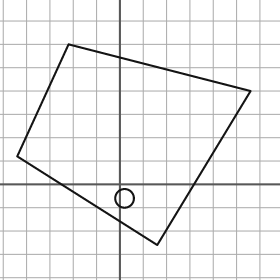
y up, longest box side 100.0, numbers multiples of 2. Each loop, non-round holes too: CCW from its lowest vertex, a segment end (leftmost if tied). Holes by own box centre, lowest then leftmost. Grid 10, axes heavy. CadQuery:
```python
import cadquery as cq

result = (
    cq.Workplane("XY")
    .moveTo(16.0, -26.0)
    .lineTo(56.0, 40.0)
    .lineTo(-22.0, 60.0)
    .lineTo(-44.0, 12.0)
    .close()
    .moveTo(2.0, -6.0)
    .circle(4.0)
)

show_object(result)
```